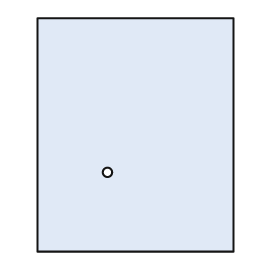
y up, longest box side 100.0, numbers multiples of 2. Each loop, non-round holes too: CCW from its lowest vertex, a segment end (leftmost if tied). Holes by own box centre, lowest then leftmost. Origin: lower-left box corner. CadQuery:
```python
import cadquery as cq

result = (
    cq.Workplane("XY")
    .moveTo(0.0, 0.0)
    .lineTo(84.0, 0.0)
    .lineTo(84.0, 100.0)
    .lineTo(0.0, 100.0)
    .close()
    .moveTo(30.0, 34.0)
    .circle(2.0)
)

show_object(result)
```